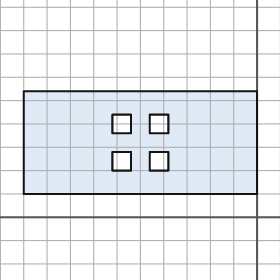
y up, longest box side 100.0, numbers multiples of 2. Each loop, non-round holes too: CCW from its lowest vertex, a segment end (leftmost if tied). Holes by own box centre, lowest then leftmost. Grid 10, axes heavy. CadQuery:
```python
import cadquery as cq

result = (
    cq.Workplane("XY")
    .moveTo(-100.0, 10.0)
    .lineTo(0.0, 10.0)
    .lineTo(0.0, 54.0)
    .lineTo(-100.0, 54.0)
    .close()
    .moveTo(-62.0, 20.0)
    .lineTo(-54.0, 20.0)
    .lineTo(-54.0, 28.0)
    .lineTo(-62.0, 28.0)
    .close()
    .moveTo(-46.0, 20.0)
    .lineTo(-38.0, 20.0)
    .lineTo(-38.0, 28.0)
    .lineTo(-46.0, 28.0)
    .close()
    .moveTo(-62.0, 36.0)
    .lineTo(-54.0, 36.0)
    .lineTo(-54.0, 44.0)
    .lineTo(-62.0, 44.0)
    .close()
    .moveTo(-46.0, 36.0)
    .lineTo(-38.0, 36.0)
    .lineTo(-38.0, 44.0)
    .lineTo(-46.0, 44.0)
    .close()
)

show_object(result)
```